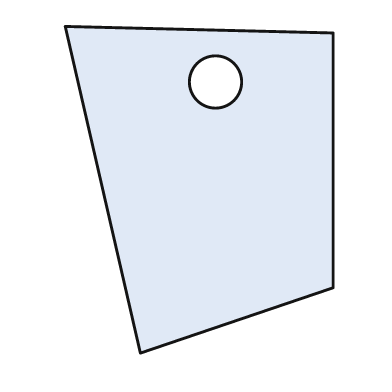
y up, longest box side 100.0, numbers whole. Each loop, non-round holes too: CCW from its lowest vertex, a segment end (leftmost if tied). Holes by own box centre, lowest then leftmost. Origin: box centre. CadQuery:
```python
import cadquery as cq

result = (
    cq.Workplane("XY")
    .moveTo(-18.0, -50.0)
    .lineTo(41.0, -30.0)
    .lineTo(41.0, 48.0)
    .lineTo(-41.0, 50.0)
    .close()
    .moveTo(5.0, 33.0)
    .circle(8.0)
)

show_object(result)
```